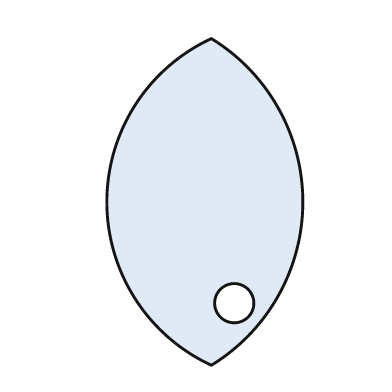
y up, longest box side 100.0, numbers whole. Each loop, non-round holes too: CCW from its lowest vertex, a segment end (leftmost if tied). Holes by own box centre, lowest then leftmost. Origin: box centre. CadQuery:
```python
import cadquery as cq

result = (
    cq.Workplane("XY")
    .moveTo(2.0, -50.0)
    .threePointArc((30.0, 0.0), (2.0, 50.0))
    .threePointArc((-30.0, 0.0), (2.0, -50.0))
    .close()
    .moveTo(9.0, -31.0)
    .circle(6.0)
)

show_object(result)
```